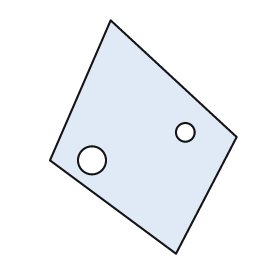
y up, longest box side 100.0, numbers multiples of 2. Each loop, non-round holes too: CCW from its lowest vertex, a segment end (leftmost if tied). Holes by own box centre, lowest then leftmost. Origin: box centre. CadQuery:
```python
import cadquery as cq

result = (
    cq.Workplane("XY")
    .moveTo(14.0, -50.0)
    .lineTo(40.0, 0.0)
    .lineTo(-14.0, 50.0)
    .lineTo(-40.0, -10.0)
    .close()
    .moveTo(-22.0, -10.0)
    .circle(6.0)
    .moveTo(18.0, 2.0)
    .circle(4.0)
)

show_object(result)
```